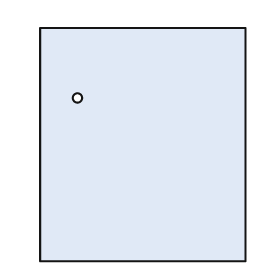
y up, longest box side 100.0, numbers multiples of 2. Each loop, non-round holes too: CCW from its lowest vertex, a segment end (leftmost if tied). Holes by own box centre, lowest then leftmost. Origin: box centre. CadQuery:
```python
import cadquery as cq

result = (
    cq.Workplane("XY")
    .moveTo(-44.0, -50.0)
    .lineTo(44.0, -50.0)
    .lineTo(44.0, 50.0)
    .lineTo(-44.0, 50.0)
    .close()
    .moveTo(-28.0, 20.0)
    .circle(2.0)
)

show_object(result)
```